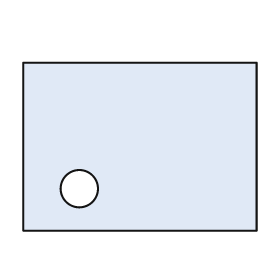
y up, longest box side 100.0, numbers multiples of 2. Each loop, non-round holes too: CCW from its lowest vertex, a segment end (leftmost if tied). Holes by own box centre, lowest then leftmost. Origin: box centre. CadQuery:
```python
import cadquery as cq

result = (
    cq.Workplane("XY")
    .moveTo(-50.0, -36.0)
    .lineTo(50.0, -36.0)
    .lineTo(50.0, 36.0)
    .lineTo(-50.0, 36.0)
    .close()
    .moveTo(-26.0, -18.0)
    .circle(8.0)
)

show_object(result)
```